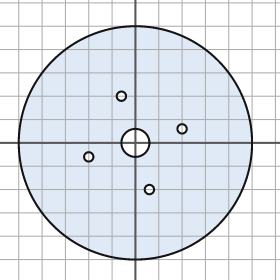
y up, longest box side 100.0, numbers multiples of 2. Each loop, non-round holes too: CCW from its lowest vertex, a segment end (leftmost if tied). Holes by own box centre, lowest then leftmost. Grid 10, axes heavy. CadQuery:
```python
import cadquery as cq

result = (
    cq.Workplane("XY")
    .moveTo(0.0, 0.0)
    .circle(50.0)
    .moveTo(6.0, -20.0)
    .circle(2.0)
    .moveTo(-20.0, -6.0)
    .circle(2.0)
    .moveTo(0.0, 0.0)
    .circle(6.0)
    .moveTo(20.0, 6.0)
    .circle(2.0)
    .moveTo(-6.0, 20.0)
    .circle(2.0)
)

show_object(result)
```